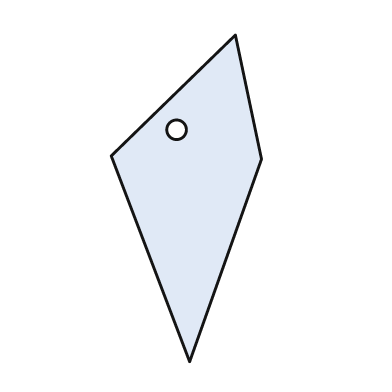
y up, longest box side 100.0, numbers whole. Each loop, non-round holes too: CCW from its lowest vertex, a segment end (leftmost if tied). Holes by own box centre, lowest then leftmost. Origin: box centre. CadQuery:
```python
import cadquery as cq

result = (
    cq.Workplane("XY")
    .moveTo(1.0, -50.0)
    .lineTo(23.0, 12.0)
    .lineTo(15.0, 50.0)
    .lineTo(-23.0, 13.0)
    .close()
    .moveTo(-3.0, 21.0)
    .circle(3.0)
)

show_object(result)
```